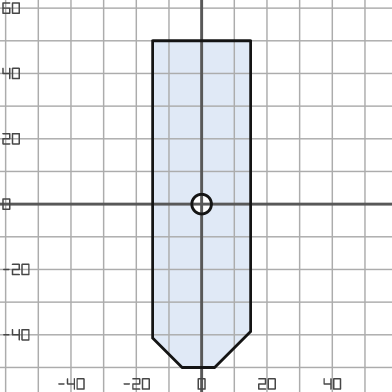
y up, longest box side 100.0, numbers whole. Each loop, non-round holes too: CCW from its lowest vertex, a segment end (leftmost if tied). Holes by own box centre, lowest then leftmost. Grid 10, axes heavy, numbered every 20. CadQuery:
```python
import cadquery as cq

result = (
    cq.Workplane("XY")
    .moveTo(-6.0, -50.0)
    .lineTo(4.0, -50.0)
    .lineTo(15.0, -39.0)
    .lineTo(15.0, 50.0)
    .lineTo(-15.0, 50.0)
    .lineTo(-15.0, -41.0)
    .close()
    .moveTo(0.0, 0.0)
    .circle(3.0)
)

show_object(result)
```